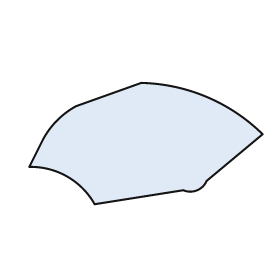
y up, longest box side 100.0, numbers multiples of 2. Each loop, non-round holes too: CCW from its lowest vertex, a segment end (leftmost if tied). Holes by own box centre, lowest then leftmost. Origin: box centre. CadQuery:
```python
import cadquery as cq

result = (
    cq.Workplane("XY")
    .moveTo(-22.0, -26.0)
    .lineTo(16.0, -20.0)
    .threePointArc((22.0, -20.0), (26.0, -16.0))
    .lineTo(50.0, 4.0)
    .threePointArc((26.0, 20.0), (-2.0, 26.0))
    .lineTo(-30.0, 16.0)
    .threePointArc((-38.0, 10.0), (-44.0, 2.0))
    .lineTo(-50.0, -10.0)
    .threePointArc((-34.0, -14.0), (-22.0, -26.0))
    .close()
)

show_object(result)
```